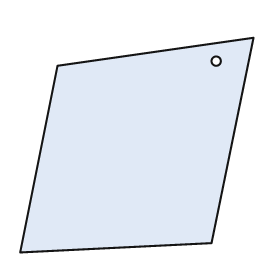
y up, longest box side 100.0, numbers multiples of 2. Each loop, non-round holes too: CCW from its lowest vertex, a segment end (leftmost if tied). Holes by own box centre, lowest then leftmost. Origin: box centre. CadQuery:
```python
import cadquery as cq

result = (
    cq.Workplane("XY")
    .moveTo(-50.0, -46.0)
    .lineTo(32.0, -42.0)
    .lineTo(50.0, 46.0)
    .lineTo(-34.0, 34.0)
    .close()
    .moveTo(34.0, 36.0)
    .circle(2.0)
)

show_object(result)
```